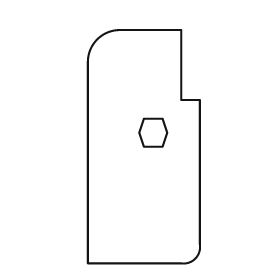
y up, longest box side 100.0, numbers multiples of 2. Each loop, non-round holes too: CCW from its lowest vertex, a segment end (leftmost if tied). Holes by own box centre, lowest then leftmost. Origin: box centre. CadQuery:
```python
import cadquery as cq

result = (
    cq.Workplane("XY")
    .moveTo(-24.0, -50.0)
    .lineTo(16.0, -50.0)
    .threePointArc((22.0, -48.0), (24.0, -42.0))
    .lineTo(24.0, 20.0)
    .lineTo(16.0, 20.0)
    .lineTo(16.0, 50.0)
    .lineTo(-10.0, 50.0)
    .threePointArc((-20.0, 46.0), (-24.0, 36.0))
    .close()
    .moveTo(0.0, 0.0)
    .lineTo(8.0, 0.0)
    .lineTo(10.0, 6.0)
    .lineTo(8.0, 12.0)
    .lineTo(0.0, 12.0)
    .lineTo(-2.0, 6.0)
    .close()
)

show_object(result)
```